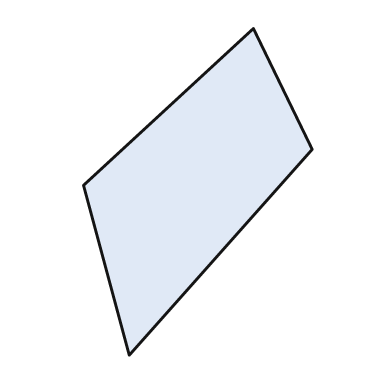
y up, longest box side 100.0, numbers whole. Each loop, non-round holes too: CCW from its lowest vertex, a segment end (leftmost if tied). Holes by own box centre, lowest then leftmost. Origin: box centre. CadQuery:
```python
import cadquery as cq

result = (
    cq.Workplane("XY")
    .moveTo(-21.0, -50.0)
    .lineTo(35.0, 13.0)
    .lineTo(17.0, 50.0)
    .lineTo(-35.0, 2.0)
    .close()
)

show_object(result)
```